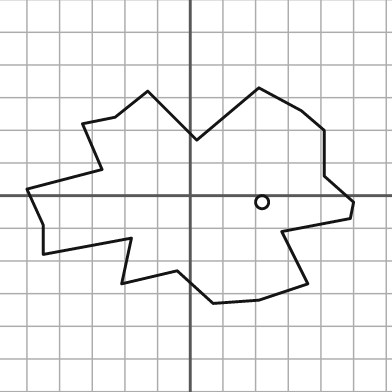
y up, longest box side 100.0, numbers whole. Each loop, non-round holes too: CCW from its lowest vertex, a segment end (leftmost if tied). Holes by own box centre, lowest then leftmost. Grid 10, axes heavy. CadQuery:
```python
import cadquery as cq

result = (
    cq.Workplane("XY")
    .moveTo(7.0, -33.0)
    .lineTo(21.0, -32.0)
    .lineTo(36.0, -27.0)
    .lineTo(28.0, -11.0)
    .lineTo(49.0, -7.0)
    .lineTo(50.0, -2.0)
    .lineTo(41.0, 6.0)
    .lineTo(41.0, 20.0)
    .lineTo(34.0, 26.0)
    .lineTo(21.0, 33.0)
    .lineTo(2.0, 17.0)
    .lineTo(-13.0, 32.0)
    .lineTo(-23.0, 24.0)
    .lineTo(-33.0, 22.0)
    .lineTo(-27.0, 8.0)
    .lineTo(-50.0, 2.0)
    .lineTo(-45.0, -9.0)
    .lineTo(-45.0, -18.0)
    .lineTo(-18.0, -13.0)
    .lineTo(-21.0, -27.0)
    .lineTo(-4.0, -23.0)
    .close()
    .moveTo(22.0, -2.0)
    .circle(2.0)
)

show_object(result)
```